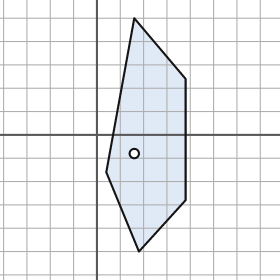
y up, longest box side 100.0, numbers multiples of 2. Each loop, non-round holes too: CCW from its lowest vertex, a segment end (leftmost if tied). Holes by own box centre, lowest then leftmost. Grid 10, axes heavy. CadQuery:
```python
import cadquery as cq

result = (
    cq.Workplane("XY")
    .moveTo(18.0, -50.0)
    .lineTo(38.0, -28.0)
    .lineTo(38.0, 24.0)
    .lineTo(16.0, 50.0)
    .lineTo(4.0, -16.0)
    .close()
    .moveTo(16.0, -8.0)
    .circle(2.0)
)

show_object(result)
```